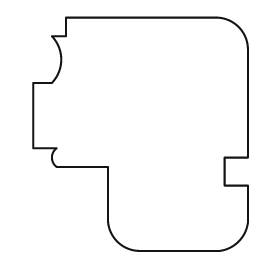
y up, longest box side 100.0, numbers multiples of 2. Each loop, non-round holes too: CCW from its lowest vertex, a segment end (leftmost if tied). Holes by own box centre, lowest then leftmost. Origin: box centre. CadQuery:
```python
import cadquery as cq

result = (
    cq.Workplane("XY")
    .moveTo(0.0, -50.0)
    .lineTo(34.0, -50.0)
    .threePointArc((42.0, -46.0), (46.0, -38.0))
    .lineTo(46.0, -22.0)
    .lineTo(36.0, -22.0)
    .lineTo(36.0, -10.0)
    .lineTo(46.0, -10.0)
    .lineTo(46.0, 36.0)
    .threePointArc((42.0, 46.0), (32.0, 50.0))
    .lineTo(-32.0, 50.0)
    .lineTo(-32.0, 42.0)
    .lineTo(-38.0, 42.0)
    .threePointArc((-34.0, 32.0), (-38.0, 22.0))
    .lineTo(-46.0, 22.0)
    .lineTo(-46.0, -6.0)
    .lineTo(-36.0, -6.0)
    .threePointArc((-38.0, -10.0), (-36.0, -14.0))
    .lineTo(-14.0, -14.0)
    .lineTo(-14.0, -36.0)
    .threePointArc((-10.0, -46.0), (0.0, -50.0))
    .close()
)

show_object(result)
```